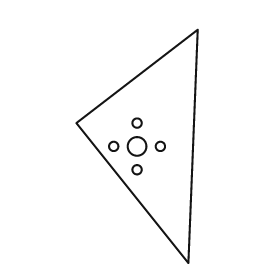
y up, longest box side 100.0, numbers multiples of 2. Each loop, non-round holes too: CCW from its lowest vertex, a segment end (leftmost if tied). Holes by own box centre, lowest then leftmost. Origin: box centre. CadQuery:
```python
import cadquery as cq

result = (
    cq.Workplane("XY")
    .moveTo(22.0, -50.0)
    .lineTo(26.0, 50.0)
    .lineTo(-26.0, 10.0)
    .close()
    .moveTo(0.0, -10.0)
    .circle(2.0)
    .moveTo(-10.0, 0.0)
    .circle(2.0)
    .moveTo(0.0, 0.0)
    .circle(4.0)
    .moveTo(10.0, 0.0)
    .circle(2.0)
    .moveTo(0.0, 10.0)
    .circle(2.0)
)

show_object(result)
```